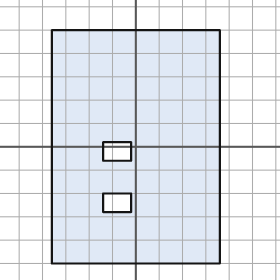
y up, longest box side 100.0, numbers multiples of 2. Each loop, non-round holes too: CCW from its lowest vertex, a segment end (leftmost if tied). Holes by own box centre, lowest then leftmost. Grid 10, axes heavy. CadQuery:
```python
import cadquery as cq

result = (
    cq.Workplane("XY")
    .moveTo(-36.0, -50.0)
    .lineTo(36.0, -50.0)
    .lineTo(36.0, 50.0)
    .lineTo(-36.0, 50.0)
    .close()
    .moveTo(-14.0, -28.0)
    .lineTo(-2.0, -28.0)
    .lineTo(-2.0, -20.0)
    .lineTo(-14.0, -20.0)
    .close()
    .moveTo(-14.0, -6.0)
    .lineTo(-2.0, -6.0)
    .lineTo(-2.0, 2.0)
    .lineTo(-14.0, 2.0)
    .close()
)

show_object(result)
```